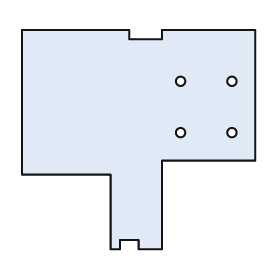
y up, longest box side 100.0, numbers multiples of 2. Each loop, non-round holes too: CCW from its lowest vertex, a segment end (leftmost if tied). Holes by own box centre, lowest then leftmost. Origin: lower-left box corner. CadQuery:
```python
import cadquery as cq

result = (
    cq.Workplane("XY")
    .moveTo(38.0, 0.0)
    .lineTo(42.0, 0.0)
    .lineTo(42.0, 4.0)
    .lineTo(50.0, 4.0)
    .lineTo(50.0, 0.0)
    .lineTo(60.0, 0.0)
    .lineTo(60.0, 38.0)
    .lineTo(100.0, 38.0)
    .lineTo(100.0, 94.0)
    .lineTo(60.0, 94.0)
    .lineTo(60.0, 90.0)
    .lineTo(46.0, 90.0)
    .lineTo(46.0, 94.0)
    .lineTo(0.0, 94.0)
    .lineTo(0.0, 32.0)
    .lineTo(38.0, 32.0)
    .close()
    .moveTo(68.0, 50.0)
    .circle(2.0)
    .moveTo(90.0, 50.0)
    .circle(2.0)
    .moveTo(68.0, 72.0)
    .circle(2.0)
    .moveTo(90.0, 72.0)
    .circle(2.0)
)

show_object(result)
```